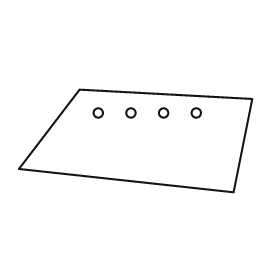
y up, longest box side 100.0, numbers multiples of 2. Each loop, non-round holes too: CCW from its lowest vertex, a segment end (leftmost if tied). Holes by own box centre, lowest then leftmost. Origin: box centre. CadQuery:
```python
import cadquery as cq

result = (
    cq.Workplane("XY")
    .moveTo(42.0, -22.0)
    .lineTo(50.0, 18.0)
    .lineTo(-24.0, 22.0)
    .lineTo(-50.0, -12.0)
    .close()
    .moveTo(-16.0, 12.0)
    .circle(2.0)
    .moveTo(-2.0, 12.0)
    .circle(2.0)
    .moveTo(12.0, 12.0)
    .circle(2.0)
    .moveTo(26.0, 12.0)
    .circle(2.0)
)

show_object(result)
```